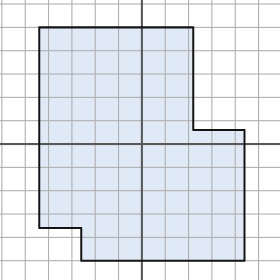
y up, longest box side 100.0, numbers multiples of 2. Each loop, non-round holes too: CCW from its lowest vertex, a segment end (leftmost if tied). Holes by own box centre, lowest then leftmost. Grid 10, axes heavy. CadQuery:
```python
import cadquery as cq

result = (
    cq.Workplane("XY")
    .moveTo(-26.0, -50.0)
    .lineTo(44.0, -50.0)
    .lineTo(44.0, 6.0)
    .lineTo(22.0, 6.0)
    .lineTo(22.0, 50.0)
    .lineTo(-44.0, 50.0)
    .lineTo(-44.0, -36.0)
    .lineTo(-26.0, -36.0)
    .close()
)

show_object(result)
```